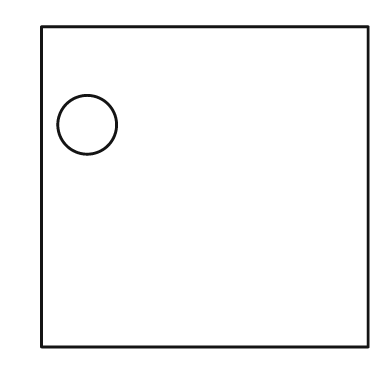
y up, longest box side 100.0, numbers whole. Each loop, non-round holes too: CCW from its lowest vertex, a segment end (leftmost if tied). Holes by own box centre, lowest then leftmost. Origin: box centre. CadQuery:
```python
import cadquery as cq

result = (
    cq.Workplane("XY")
    .moveTo(-50.0, -49.0)
    .lineTo(50.0, -49.0)
    .lineTo(50.0, 49.0)
    .lineTo(-50.0, 49.0)
    .close()
    .moveTo(-36.0, 19.0)
    .circle(9.0)
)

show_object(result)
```